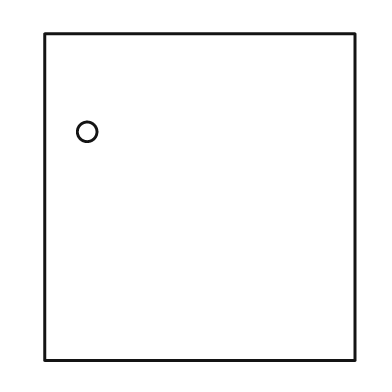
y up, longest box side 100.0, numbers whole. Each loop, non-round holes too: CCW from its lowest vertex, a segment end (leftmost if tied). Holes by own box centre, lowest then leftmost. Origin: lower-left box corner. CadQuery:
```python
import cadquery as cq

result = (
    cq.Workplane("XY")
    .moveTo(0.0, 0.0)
    .lineTo(95.0, 0.0)
    .lineTo(95.0, 100.0)
    .lineTo(0.0, 100.0)
    .close()
    .moveTo(13.0, 70.0)
    .circle(3.0)
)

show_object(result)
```